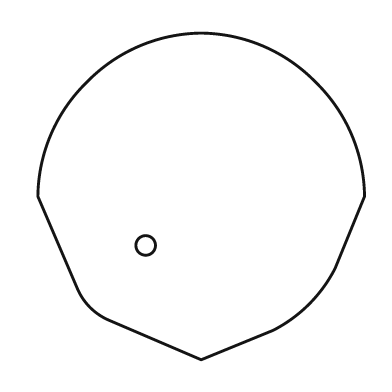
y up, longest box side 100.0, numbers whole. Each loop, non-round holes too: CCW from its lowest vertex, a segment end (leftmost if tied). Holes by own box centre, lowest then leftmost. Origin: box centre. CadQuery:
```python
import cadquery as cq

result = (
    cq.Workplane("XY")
    .moveTo(0.0, -50.0)
    .lineTo(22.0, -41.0)
    .threePointArc((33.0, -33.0), (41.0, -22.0))
    .lineTo(50.0, 0.0)
    .threePointArc((46.0, 19.0), (35.0, 35.0))
    .threePointArc((19.0, 46.0), (0.0, 50.0))
    .threePointArc((-19.0, 46.0), (-35.0, 35.0))
    .threePointArc((-46.0, 19.0), (-50.0, 0.0))
    .lineTo(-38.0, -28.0)
    .threePointArc((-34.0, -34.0), (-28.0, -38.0))
    .close()
    .moveTo(-17.0, -15.0)
    .circle(3.0)
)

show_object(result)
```